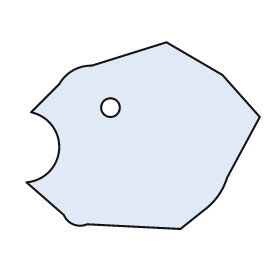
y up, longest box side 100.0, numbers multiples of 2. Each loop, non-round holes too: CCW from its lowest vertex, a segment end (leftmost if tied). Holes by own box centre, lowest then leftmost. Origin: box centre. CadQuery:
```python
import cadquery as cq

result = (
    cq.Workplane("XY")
    .moveTo(16.0, -40.0)
    .lineTo(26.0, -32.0)
    .threePointArc((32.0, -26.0), (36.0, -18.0))
    .lineTo(50.0, 8.0)
    .lineTo(34.0, 26.0)
    .lineTo(10.0, 40.0)
    .lineTo(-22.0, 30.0)
    .threePointArc((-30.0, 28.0), (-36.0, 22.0))
    .lineTo(-48.0, 10.0)
    .threePointArc((-36.0, -6.0), (-50.0, -20.0))
    .lineTo(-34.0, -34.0)
    .threePointArc((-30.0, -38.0), (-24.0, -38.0))
    .close()
    .moveTo(-14.0, 12.0)
    .circle(4.0)
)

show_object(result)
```